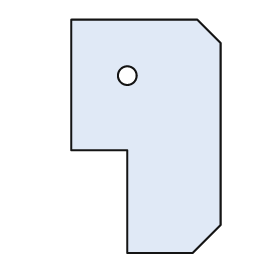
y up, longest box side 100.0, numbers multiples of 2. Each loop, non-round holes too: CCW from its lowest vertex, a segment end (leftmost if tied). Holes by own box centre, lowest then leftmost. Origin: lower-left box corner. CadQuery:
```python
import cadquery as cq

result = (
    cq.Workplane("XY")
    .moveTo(24.0, 0.0)
    .lineTo(52.0, 0.0)
    .lineTo(64.0, 12.0)
    .lineTo(64.0, 90.0)
    .lineTo(54.0, 100.0)
    .lineTo(0.0, 100.0)
    .lineTo(0.0, 44.0)
    .lineTo(24.0, 44.0)
    .close()
    .moveTo(24.0, 76.0)
    .circle(4.0)
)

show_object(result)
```